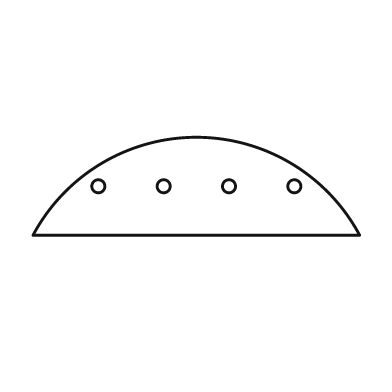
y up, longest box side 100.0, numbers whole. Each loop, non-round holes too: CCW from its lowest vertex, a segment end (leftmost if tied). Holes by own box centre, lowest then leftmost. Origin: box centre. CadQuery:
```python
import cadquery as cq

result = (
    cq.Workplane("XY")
    .moveTo(-50.0, -15.0)
    .lineTo(50.0, -15.0)
    .threePointArc((0.0, 15.0), (-50.0, -15.0))
    .close()
    .moveTo(-30.0, 0.0)
    .circle(2.0)
    .moveTo(-10.0, 0.0)
    .circle(2.0)
    .moveTo(10.0, 0.0)
    .circle(2.0)
    .moveTo(30.0, 0.0)
    .circle(2.0)
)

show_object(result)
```